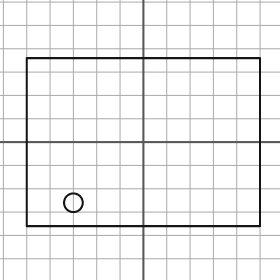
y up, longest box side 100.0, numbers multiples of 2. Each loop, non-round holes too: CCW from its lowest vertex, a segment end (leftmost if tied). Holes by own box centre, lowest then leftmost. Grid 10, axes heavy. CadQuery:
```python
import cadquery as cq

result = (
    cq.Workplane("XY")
    .moveTo(-50.0, -36.0)
    .lineTo(50.0, -36.0)
    .lineTo(50.0, 36.0)
    .lineTo(-50.0, 36.0)
    .close()
    .moveTo(-30.0, -26.0)
    .circle(4.0)
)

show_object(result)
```